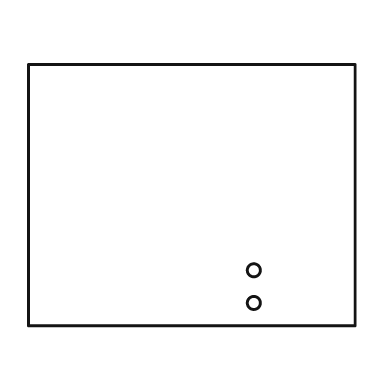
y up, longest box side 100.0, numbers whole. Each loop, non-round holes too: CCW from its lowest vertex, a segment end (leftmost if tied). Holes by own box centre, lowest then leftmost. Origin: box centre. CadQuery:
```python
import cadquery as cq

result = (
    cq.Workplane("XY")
    .moveTo(-50.0, -40.0)
    .lineTo(50.0, -40.0)
    .lineTo(50.0, 40.0)
    .lineTo(-50.0, 40.0)
    .close()
    .moveTo(19.0, -33.0)
    .circle(2.0)
    .moveTo(19.0, -23.0)
    .circle(2.0)
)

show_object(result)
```